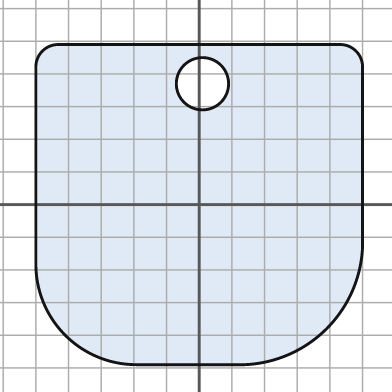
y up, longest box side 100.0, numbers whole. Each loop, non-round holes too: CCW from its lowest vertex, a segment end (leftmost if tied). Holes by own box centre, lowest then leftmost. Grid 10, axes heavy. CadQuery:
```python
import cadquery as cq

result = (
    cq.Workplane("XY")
    .moveTo(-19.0, -49.0)
    .lineTo(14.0, -49.0)
    .threePointArc((39.0, -38.0), (50.0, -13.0))
    .lineTo(50.0, 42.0)
    .threePointArc((48.0, 47.0), (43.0, 49.0))
    .lineTo(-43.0, 49.0)
    .threePointArc((-48.0, 47.0), (-50.0, 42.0))
    .lineTo(-50.0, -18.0)
    .threePointArc((-41.0, -40.0), (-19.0, -49.0))
    .close()
    .moveTo(1.0, 37.0)
    .circle(8.0)
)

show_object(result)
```